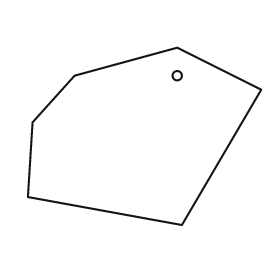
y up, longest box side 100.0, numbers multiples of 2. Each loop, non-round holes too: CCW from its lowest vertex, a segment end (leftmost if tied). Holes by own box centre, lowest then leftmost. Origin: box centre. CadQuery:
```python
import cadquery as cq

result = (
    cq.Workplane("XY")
    .moveTo(16.0, -38.0)
    .lineTo(50.0, 20.0)
    .lineTo(14.0, 38.0)
    .lineTo(-30.0, 26.0)
    .lineTo(-48.0, 6.0)
    .lineTo(-50.0, -26.0)
    .close()
    .moveTo(14.0, 26.0)
    .circle(2.0)
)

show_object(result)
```